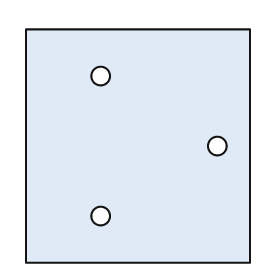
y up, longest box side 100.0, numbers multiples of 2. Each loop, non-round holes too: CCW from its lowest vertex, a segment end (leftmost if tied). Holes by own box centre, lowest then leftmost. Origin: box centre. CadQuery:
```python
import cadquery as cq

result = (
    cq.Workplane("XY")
    .moveTo(-48.0, -50.0)
    .lineTo(48.0, -50.0)
    .lineTo(48.0, 50.0)
    .lineTo(-48.0, 50.0)
    .close()
    .moveTo(-16.0, -30.0)
    .circle(4.0)
    .moveTo(34.0, 0.0)
    .circle(4.0)
    .moveTo(-16.0, 30.0)
    .circle(4.0)
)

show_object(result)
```